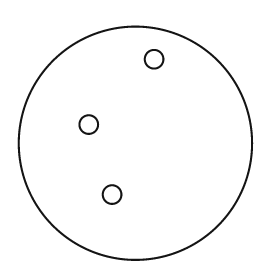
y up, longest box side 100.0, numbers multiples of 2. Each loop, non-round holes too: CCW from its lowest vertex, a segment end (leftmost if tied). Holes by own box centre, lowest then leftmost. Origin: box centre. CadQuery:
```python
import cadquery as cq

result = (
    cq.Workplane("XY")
    .moveTo(0.0, 0.0)
    .circle(50.0)
    .moveTo(-10.0, -22.0)
    .circle(4.0)
    .moveTo(-20.0, 8.0)
    .circle(4.0)
    .moveTo(8.0, 36.0)
    .circle(4.0)
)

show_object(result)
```